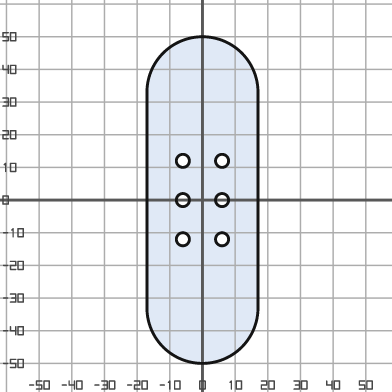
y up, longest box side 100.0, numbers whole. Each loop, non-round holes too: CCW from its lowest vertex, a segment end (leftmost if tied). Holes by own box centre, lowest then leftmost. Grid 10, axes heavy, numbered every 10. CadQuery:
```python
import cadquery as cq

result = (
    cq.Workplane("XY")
    .moveTo(-17.0, -33.0)
    .threePointArc((0.0, -50.0), (17.0, -33.0))
    .lineTo(17.0, 33.0)
    .threePointArc((0.0, 50.0), (-17.0, 33.0))
    .close()
    .moveTo(-6.0, -12.0)
    .circle(2.0)
    .moveTo(6.0, -12.0)
    .circle(2.0)
    .moveTo(-6.0, 0.0)
    .circle(2.0)
    .moveTo(6.0, 0.0)
    .circle(2.0)
    .moveTo(-6.0, 12.0)
    .circle(2.0)
    .moveTo(6.0, 12.0)
    .circle(2.0)
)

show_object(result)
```